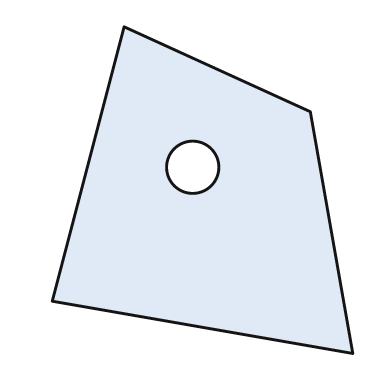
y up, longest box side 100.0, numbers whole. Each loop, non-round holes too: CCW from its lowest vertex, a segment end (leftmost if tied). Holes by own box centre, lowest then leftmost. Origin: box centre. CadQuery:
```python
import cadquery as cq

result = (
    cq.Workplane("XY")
    .moveTo(46.0, -50.0)
    .lineTo(33.0, 24.0)
    .lineTo(-24.0, 50.0)
    .lineTo(-46.0, -34.0)
    .close()
    .moveTo(-3.0, 7.0)
    .circle(8.0)
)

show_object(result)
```